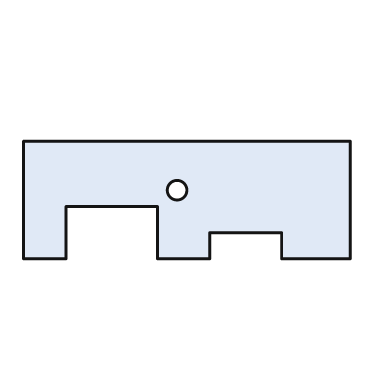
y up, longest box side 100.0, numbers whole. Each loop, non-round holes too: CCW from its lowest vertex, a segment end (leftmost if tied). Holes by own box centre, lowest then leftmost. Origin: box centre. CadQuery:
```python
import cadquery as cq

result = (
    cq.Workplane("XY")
    .moveTo(-50.0, -18.0)
    .lineTo(-37.0, -18.0)
    .lineTo(-37.0, -2.0)
    .lineTo(-9.0, -2.0)
    .lineTo(-9.0, -18.0)
    .lineTo(7.0, -18.0)
    .lineTo(7.0, -10.0)
    .lineTo(29.0, -10.0)
    .lineTo(29.0, -18.0)
    .lineTo(50.0, -18.0)
    .lineTo(50.0, 18.0)
    .lineTo(-50.0, 18.0)
    .close()
    .moveTo(-3.0, 3.0)
    .circle(3.0)
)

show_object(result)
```